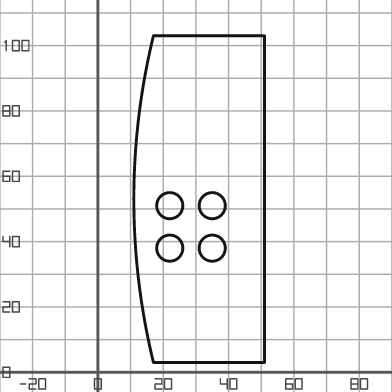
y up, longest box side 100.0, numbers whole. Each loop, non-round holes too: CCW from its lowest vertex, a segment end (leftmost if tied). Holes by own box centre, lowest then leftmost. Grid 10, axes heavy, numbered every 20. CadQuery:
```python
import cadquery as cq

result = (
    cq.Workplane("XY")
    .moveTo(17.0, 3.0)
    .lineTo(51.0, 3.0)
    .lineTo(51.0, 103.0)
    .lineTo(17.0, 103.0)
    .threePointArc((11.0, 53.0), (17.0, 3.0))
    .close()
    .moveTo(22.0, 38.0)
    .circle(4.0)
    .moveTo(35.0, 38.0)
    .circle(4.0)
    .moveTo(22.0, 51.0)
    .circle(4.0)
    .moveTo(35.0, 51.0)
    .circle(4.0)
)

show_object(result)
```